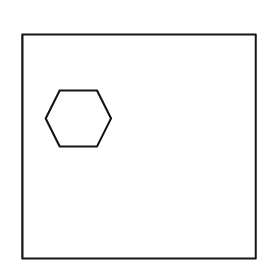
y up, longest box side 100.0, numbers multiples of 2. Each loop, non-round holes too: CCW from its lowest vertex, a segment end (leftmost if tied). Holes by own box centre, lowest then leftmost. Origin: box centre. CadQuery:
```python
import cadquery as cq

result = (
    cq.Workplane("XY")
    .moveTo(-50.0, -48.0)
    .lineTo(50.0, -48.0)
    .lineTo(50.0, 48.0)
    .lineTo(-50.0, 48.0)
    .close()
    .moveTo(-34.0, 0.0)
    .lineTo(-18.0, 0.0)
    .lineTo(-12.0, 12.0)
    .lineTo(-18.0, 24.0)
    .lineTo(-34.0, 24.0)
    .lineTo(-40.0, 12.0)
    .close()
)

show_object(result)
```